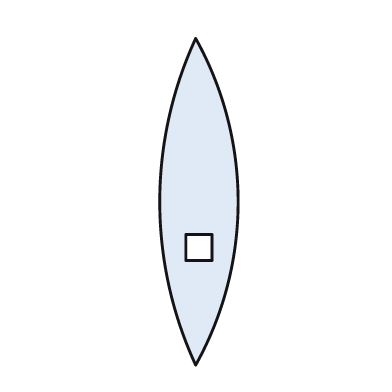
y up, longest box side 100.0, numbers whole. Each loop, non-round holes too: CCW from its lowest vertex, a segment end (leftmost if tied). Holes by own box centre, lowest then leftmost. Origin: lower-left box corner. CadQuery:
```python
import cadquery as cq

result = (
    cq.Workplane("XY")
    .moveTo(11.0, 0.0)
    .threePointArc((24.0, 50.0), (11.0, 100.0))
    .threePointArc((0.0, 50.0), (11.0, 0.0))
    .close()
    .moveTo(8.0, 32.0)
    .lineTo(16.0, 32.0)
    .lineTo(16.0, 40.0)
    .lineTo(8.0, 40.0)
    .close()
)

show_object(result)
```